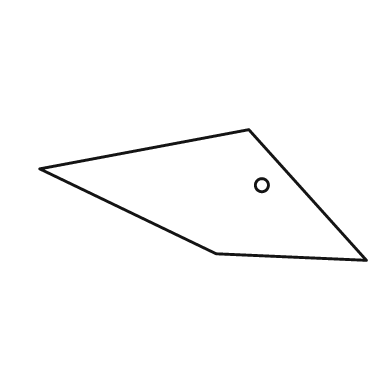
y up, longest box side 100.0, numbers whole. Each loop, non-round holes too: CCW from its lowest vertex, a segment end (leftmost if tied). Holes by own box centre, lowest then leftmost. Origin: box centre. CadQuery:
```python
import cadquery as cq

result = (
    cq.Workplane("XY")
    .moveTo(50.0, -20.0)
    .lineTo(14.0, 20.0)
    .lineTo(-50.0, 8.0)
    .lineTo(4.0, -18.0)
    .close()
    .moveTo(18.0, 3.0)
    .circle(2.0)
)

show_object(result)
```